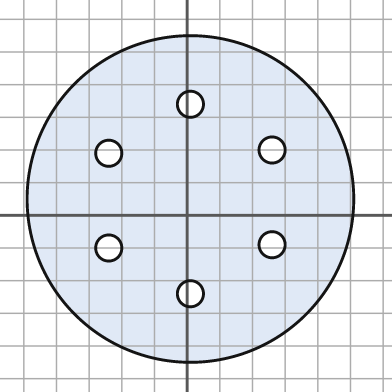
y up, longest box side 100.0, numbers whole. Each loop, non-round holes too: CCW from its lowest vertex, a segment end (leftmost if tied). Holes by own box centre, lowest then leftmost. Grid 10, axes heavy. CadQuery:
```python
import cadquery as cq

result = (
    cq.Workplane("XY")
    .moveTo(1.0, 5.0)
    .circle(50.0)
    .moveTo(1.0, -24.0)
    .circle(4.0)
    .moveTo(-24.0, -10.0)
    .circle(4.0)
    .moveTo(26.0, -9.0)
    .circle(4.0)
    .moveTo(-24.0, 19.0)
    .circle(4.0)
    .moveTo(26.0, 20.0)
    .circle(4.0)
    .moveTo(1.0, 34.0)
    .circle(4.0)
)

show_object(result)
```